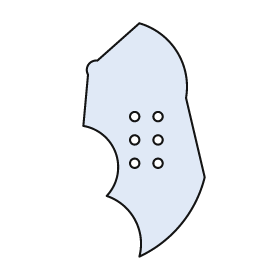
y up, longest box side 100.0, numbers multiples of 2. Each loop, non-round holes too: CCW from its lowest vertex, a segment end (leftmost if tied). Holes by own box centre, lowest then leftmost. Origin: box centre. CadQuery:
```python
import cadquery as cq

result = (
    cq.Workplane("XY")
    .moveTo(-2.0, -50.0)
    .threePointArc((16.0, -36.0), (26.0, -16.0))
    .lineTo(18.0, 18.0)
    .threePointArc((14.0, 38.0), (-2.0, 50.0))
    .lineTo(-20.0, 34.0)
    .threePointArc((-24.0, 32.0), (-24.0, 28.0))
    .lineTo(-26.0, 6.0)
    .threePointArc((-12.0, -6.0), (-16.0, -24.0))
    .threePointArc((-4.0, -34.0), (-2.0, -50.0))
    .close()
    .moveTo(-4.0, -10.0)
    .circle(2.0)
    .moveTo(6.0, -10.0)
    .circle(2.0)
    .moveTo(-4.0, 0.0)
    .circle(2.0)
    .moveTo(6.0, 0.0)
    .circle(2.0)
    .moveTo(-4.0, 10.0)
    .circle(2.0)
    .moveTo(6.0, 10.0)
    .circle(2.0)
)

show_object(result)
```